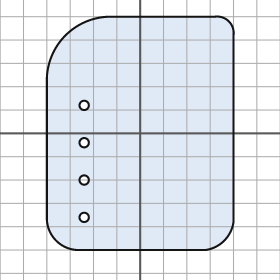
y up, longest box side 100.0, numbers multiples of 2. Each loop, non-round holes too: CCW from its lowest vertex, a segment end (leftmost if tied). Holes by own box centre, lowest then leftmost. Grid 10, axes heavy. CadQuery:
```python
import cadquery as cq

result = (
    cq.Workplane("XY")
    .moveTo(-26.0, -50.0)
    .lineTo(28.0, -50.0)
    .threePointArc((36.0, -46.0), (40.0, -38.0))
    .lineTo(40.0, 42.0)
    .threePointArc((38.0, 48.0), (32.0, 50.0))
    .lineTo(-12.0, 50.0)
    .threePointArc((-32.0, 42.0), (-40.0, 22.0))
    .lineTo(-40.0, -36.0)
    .threePointArc((-36.0, -46.0), (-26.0, -50.0))
    .close()
    .moveTo(-24.0, -36.0)
    .circle(2.0)
    .moveTo(-24.0, -20.0)
    .circle(2.0)
    .moveTo(-24.0, -4.0)
    .circle(2.0)
    .moveTo(-24.0, 12.0)
    .circle(2.0)
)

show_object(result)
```